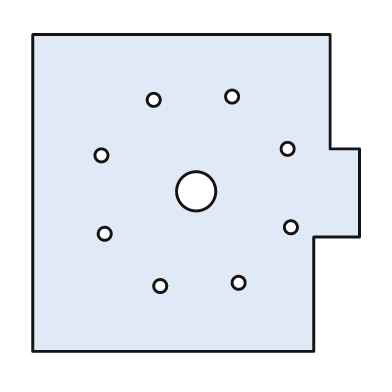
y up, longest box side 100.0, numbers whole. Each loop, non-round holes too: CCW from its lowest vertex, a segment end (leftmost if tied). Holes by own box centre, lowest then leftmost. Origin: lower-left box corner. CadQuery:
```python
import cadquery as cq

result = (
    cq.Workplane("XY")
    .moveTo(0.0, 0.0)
    .lineTo(86.0, 0.0)
    .lineTo(86.0, 35.0)
    .lineTo(100.0, 35.0)
    .lineTo(100.0, 62.0)
    .lineTo(91.0, 62.0)
    .lineTo(91.0, 97.0)
    .lineTo(0.0, 97.0)
    .close()
    .moveTo(39.0, 20.0)
    .circle(2.0)
    .moveTo(63.0, 21.0)
    .circle(2.0)
    .moveTo(22.0, 36.0)
    .circle(2.0)
    .moveTo(79.0, 38.0)
    .circle(2.0)
    .moveTo(50.0, 49.0)
    .circle(6.0)
    .moveTo(21.0, 60.0)
    .circle(2.0)
    .moveTo(78.0, 62.0)
    .circle(2.0)
    .moveTo(37.0, 77.0)
    .circle(2.0)
    .moveTo(61.0, 78.0)
    .circle(2.0)
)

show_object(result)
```